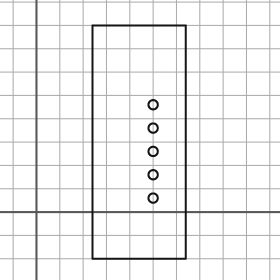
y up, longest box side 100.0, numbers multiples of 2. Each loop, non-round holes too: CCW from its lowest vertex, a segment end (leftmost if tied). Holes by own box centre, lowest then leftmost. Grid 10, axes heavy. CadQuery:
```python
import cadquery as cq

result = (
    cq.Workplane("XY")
    .moveTo(24.0, -20.0)
    .lineTo(64.0, -20.0)
    .lineTo(64.0, 80.0)
    .lineTo(24.0, 80.0)
    .close()
    .moveTo(50.0, 6.0)
    .circle(2.0)
    .moveTo(50.0, 16.0)
    .circle(2.0)
    .moveTo(50.0, 26.0)
    .circle(2.0)
    .moveTo(50.0, 36.0)
    .circle(2.0)
    .moveTo(50.0, 46.0)
    .circle(2.0)
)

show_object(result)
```